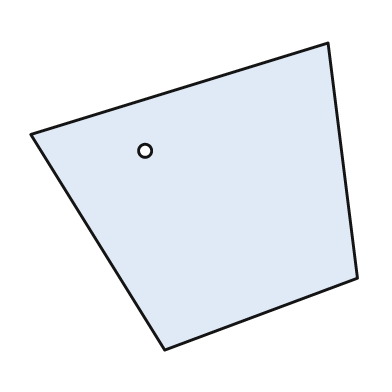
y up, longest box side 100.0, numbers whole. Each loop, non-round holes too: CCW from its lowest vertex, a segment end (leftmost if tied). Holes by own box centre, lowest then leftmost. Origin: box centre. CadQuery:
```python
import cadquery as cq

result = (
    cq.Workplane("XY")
    .moveTo(-9.0, -47.0)
    .lineTo(50.0, -25.0)
    .lineTo(41.0, 47.0)
    .lineTo(-50.0, 19.0)
    .close()
    .moveTo(-15.0, 14.0)
    .circle(2.0)
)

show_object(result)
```